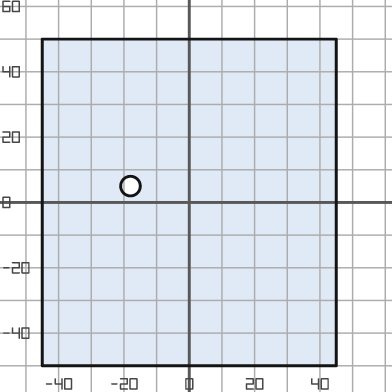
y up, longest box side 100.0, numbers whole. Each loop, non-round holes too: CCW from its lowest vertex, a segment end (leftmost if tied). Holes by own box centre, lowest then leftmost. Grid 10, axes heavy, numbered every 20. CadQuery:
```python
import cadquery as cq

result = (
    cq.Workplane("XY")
    .moveTo(-45.0, -50.0)
    .lineTo(45.0, -50.0)
    .lineTo(45.0, 50.0)
    .lineTo(-45.0, 50.0)
    .close()
    .moveTo(-18.0, 5.0)
    .circle(3.0)
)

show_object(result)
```